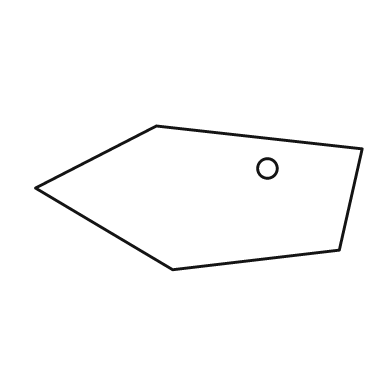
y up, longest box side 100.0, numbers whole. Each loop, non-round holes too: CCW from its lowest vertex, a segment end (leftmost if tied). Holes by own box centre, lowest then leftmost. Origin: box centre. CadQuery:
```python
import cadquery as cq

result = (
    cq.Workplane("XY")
    .moveTo(-8.0, -22.0)
    .lineTo(43.0, -16.0)
    .lineTo(50.0, 15.0)
    .lineTo(-13.0, 22.0)
    .lineTo(-50.0, 3.0)
    .close()
    .moveTo(21.0, 9.0)
    .circle(3.0)
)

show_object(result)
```